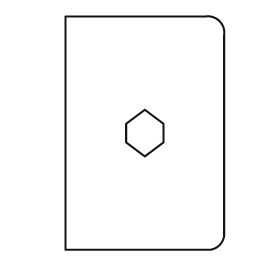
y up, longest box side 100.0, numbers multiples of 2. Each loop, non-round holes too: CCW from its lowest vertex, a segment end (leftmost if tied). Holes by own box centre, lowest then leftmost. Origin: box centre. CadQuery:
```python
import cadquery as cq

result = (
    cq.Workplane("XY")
    .moveTo(-34.0, -50.0)
    .lineTo(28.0, -50.0)
    .threePointArc((32.0, -48.0), (34.0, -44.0))
    .lineTo(34.0, 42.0)
    .threePointArc((32.0, 48.0), (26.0, 50.0))
    .lineTo(-34.0, 50.0)
    .close()
    .moveTo(0.0, -10.0)
    .lineTo(8.0, -4.0)
    .lineTo(8.0, 4.0)
    .lineTo(0.0, 10.0)
    .lineTo(-8.0, 4.0)
    .lineTo(-8.0, -4.0)
    .close()
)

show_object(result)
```